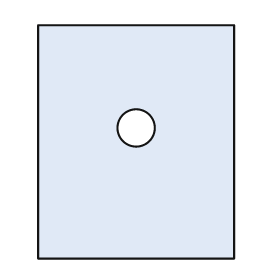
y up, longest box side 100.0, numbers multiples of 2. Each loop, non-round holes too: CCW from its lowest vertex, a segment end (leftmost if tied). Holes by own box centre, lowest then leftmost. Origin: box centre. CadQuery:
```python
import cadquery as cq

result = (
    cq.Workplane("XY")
    .moveTo(-42.0, -50.0)
    .lineTo(42.0, -50.0)
    .lineTo(42.0, 50.0)
    .lineTo(-42.0, 50.0)
    .close()
    .moveTo(0.0, 6.0)
    .circle(8.0)
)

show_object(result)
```